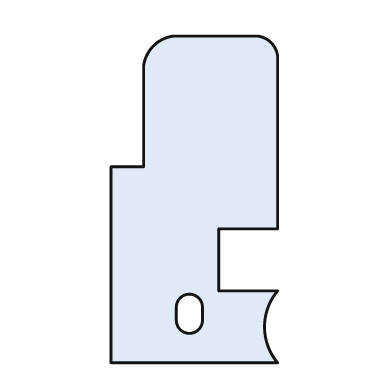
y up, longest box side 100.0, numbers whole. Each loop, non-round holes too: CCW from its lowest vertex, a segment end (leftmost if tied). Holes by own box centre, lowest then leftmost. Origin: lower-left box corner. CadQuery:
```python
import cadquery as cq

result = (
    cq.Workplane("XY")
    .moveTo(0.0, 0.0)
    .lineTo(51.0, 0.0)
    .threePointArc((47.0, 11.0), (51.0, 22.0))
    .lineTo(33.0, 22.0)
    .lineTo(33.0, 41.0)
    .lineTo(51.0, 41.0)
    .lineTo(51.0, 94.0)
    .threePointArc((49.0, 98.0), (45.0, 100.0))
    .lineTo(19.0, 100.0)
    .threePointArc((13.0, 97.0), (10.0, 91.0))
    .lineTo(10.0, 60.0)
    .lineTo(0.0, 60.0)
    .close()
    .moveTo(20.0, 13.0)
    .threePointArc((24.0, 9.0), (28.0, 13.0))
    .lineTo(28.0, 17.0)
    .threePointArc((24.0, 21.0), (20.0, 17.0))
    .close()
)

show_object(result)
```